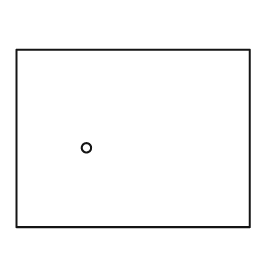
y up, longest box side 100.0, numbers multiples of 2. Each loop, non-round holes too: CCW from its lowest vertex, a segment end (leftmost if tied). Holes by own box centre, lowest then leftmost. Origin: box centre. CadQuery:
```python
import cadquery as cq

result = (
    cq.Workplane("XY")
    .moveTo(-50.0, -38.0)
    .lineTo(50.0, -38.0)
    .lineTo(50.0, 38.0)
    .lineTo(-50.0, 38.0)
    .close()
    .moveTo(-20.0, -4.0)
    .circle(2.0)
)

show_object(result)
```